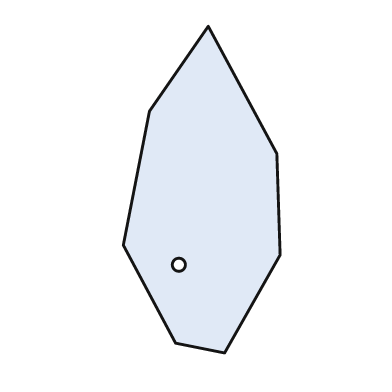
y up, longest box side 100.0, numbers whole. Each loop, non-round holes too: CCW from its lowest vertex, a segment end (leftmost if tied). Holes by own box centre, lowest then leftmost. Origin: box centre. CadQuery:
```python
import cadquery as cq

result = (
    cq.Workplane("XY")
    .moveTo(7.0, -50.0)
    .lineTo(24.0, -20.0)
    .lineTo(23.0, 11.0)
    .lineTo(2.0, 50.0)
    .lineTo(-16.0, 24.0)
    .lineTo(-24.0, -17.0)
    .lineTo(-8.0, -47.0)
    .close()
    .moveTo(-7.0, -23.0)
    .circle(2.0)
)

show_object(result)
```